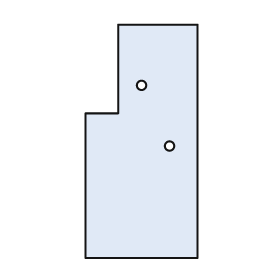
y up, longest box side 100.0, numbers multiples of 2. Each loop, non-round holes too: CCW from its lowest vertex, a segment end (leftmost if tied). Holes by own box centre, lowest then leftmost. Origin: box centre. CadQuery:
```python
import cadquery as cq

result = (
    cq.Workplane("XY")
    .moveTo(-24.0, -50.0)
    .lineTo(24.0, -50.0)
    .lineTo(24.0, 50.0)
    .lineTo(-10.0, 50.0)
    .lineTo(-10.0, 12.0)
    .lineTo(-24.0, 12.0)
    .close()
    .moveTo(12.0, -2.0)
    .circle(2.0)
    .moveTo(0.0, 24.0)
    .circle(2.0)
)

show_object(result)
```